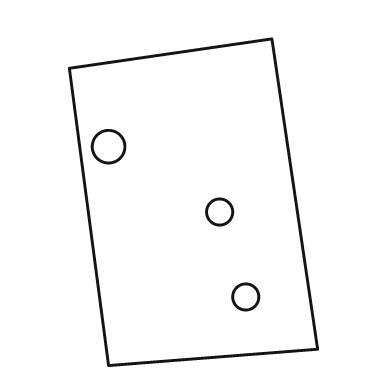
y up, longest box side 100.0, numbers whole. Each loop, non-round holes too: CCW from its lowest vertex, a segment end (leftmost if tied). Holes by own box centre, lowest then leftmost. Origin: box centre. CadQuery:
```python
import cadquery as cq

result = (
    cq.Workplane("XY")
    .moveTo(-26.0, -50.0)
    .lineTo(38.0, -45.0)
    .lineTo(24.0, 50.0)
    .lineTo(-38.0, 41.0)
    .close()
    .moveTo(16.0, -29.0)
    .circle(4.0)
    .moveTo(8.0, -3.0)
    .circle(4.0)
    .moveTo(-26.0, 17.0)
    .circle(5.0)
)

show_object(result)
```